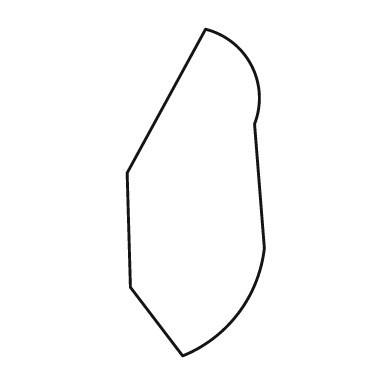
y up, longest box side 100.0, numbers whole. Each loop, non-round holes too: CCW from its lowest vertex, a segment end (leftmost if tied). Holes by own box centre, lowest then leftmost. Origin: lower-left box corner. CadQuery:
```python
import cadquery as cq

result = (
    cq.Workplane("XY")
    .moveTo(17.0, 0.0)
    .threePointArc((34.0, 13.0), (42.0, 33.0))
    .lineTo(39.0, 71.0)
    .threePointArc((38.0, 89.0), (24.0, 100.0))
    .lineTo(0.0, 56.0)
    .lineTo(1.0, 21.0)
    .close()
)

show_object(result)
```